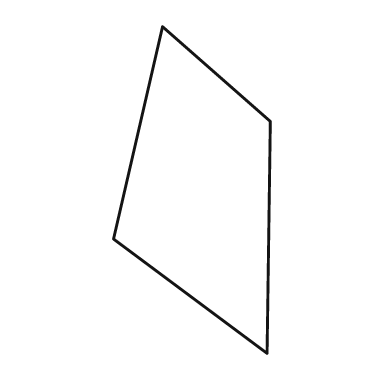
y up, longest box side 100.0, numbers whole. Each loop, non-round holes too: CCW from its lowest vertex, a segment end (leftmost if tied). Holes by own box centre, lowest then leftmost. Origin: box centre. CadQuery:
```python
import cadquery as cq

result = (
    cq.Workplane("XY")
    .moveTo(23.0, -50.0)
    .lineTo(24.0, 21.0)
    .lineTo(-9.0, 50.0)
    .lineTo(-24.0, -15.0)
    .close()
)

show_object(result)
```